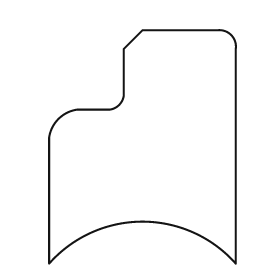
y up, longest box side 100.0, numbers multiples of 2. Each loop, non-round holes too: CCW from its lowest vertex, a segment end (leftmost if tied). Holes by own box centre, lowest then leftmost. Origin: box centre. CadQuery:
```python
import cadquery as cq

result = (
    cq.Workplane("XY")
    .moveTo(-40.0, -50.0)
    .threePointArc((0.0, -32.0), (40.0, -50.0))
    .lineTo(40.0, 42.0)
    .threePointArc((38.0, 48.0), (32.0, 50.0))
    .lineTo(0.0, 50.0)
    .lineTo(-8.0, 42.0)
    .lineTo(-8.0, 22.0)
    .threePointArc((-10.0, 18.0), (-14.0, 16.0))
    .lineTo(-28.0, 16.0)
    .threePointArc((-36.0, 12.0), (-40.0, 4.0))
    .close()
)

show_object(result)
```